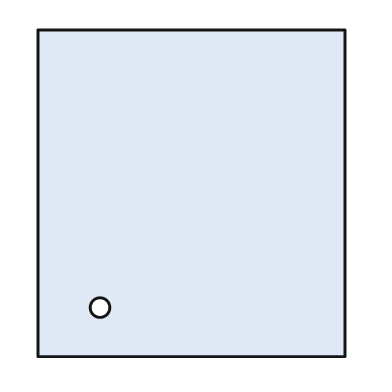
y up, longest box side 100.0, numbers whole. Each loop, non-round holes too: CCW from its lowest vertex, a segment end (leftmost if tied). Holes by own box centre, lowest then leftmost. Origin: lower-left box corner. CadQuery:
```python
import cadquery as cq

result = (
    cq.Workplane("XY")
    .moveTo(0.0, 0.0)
    .lineTo(94.0, 0.0)
    .lineTo(94.0, 100.0)
    .lineTo(0.0, 100.0)
    .close()
    .moveTo(19.0, 15.0)
    .circle(3.0)
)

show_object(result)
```